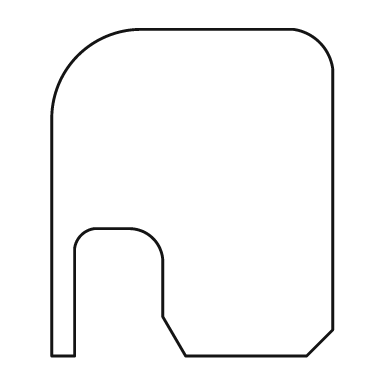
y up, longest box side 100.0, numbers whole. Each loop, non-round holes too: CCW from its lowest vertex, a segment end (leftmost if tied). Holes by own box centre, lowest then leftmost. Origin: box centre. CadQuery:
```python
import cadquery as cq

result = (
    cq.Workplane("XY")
    .moveTo(-43.0, -50.0)
    .lineTo(-36.0, -50.0)
    .lineTo(-36.0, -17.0)
    .threePointArc((-34.0, -13.0), (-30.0, -11.0))
    .lineTo(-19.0, -11.0)
    .threePointArc((-12.0, -14.0), (-9.0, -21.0))
    .lineTo(-9.0, -38.0)
    .lineTo(-2.0, -50.0)
    .lineTo(35.0, -50.0)
    .lineTo(43.0, -42.0)
    .lineTo(43.0, 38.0)
    .threePointArc((39.0, 46.0), (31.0, 50.0))
    .lineTo(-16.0, 50.0)
    .threePointArc((-35.0, 42.0), (-43.0, 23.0))
    .close()
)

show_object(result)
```